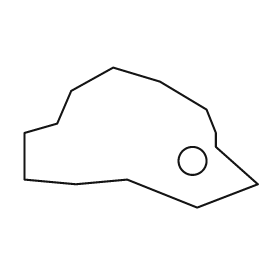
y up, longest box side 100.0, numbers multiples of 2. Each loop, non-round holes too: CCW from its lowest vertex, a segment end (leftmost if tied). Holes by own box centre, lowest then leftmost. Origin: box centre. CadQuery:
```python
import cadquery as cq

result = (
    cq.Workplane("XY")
    .moveTo(24.0, -30.0)
    .lineTo(50.0, -20.0)
    .lineTo(32.0, -4.0)
    .lineTo(32.0, 2.0)
    .lineTo(28.0, 12.0)
    .lineTo(8.0, 24.0)
    .lineTo(-12.0, 30.0)
    .lineTo(-30.0, 20.0)
    .lineTo(-36.0, 6.0)
    .lineTo(-50.0, 2.0)
    .lineTo(-50.0, -18.0)
    .lineTo(-28.0, -20.0)
    .lineTo(-6.0, -18.0)
    .close()
    .moveTo(22.0, -10.0)
    .circle(6.0)
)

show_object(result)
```